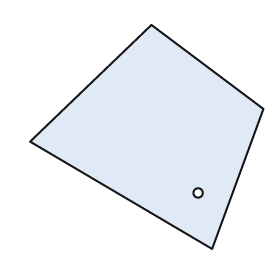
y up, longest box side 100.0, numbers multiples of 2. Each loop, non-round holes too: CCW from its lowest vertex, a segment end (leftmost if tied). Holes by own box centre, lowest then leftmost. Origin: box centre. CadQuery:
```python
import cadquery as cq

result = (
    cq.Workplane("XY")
    .moveTo(28.0, -48.0)
    .lineTo(50.0, 12.0)
    .lineTo(2.0, 48.0)
    .lineTo(-50.0, -2.0)
    .close()
    .moveTo(22.0, -24.0)
    .circle(2.0)
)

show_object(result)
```